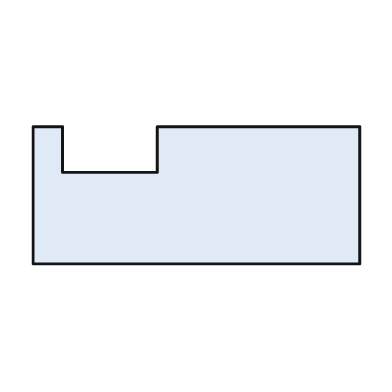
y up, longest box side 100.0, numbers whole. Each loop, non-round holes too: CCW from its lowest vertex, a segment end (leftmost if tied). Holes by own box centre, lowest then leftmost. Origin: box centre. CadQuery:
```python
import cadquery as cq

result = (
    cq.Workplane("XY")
    .moveTo(-50.0, -21.0)
    .lineTo(50.0, -21.0)
    .lineTo(50.0, 21.0)
    .lineTo(-12.0, 21.0)
    .lineTo(-12.0, 7.0)
    .lineTo(-41.0, 7.0)
    .lineTo(-41.0, 21.0)
    .lineTo(-50.0, 21.0)
    .close()
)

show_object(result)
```